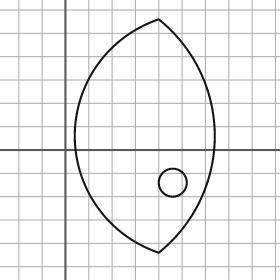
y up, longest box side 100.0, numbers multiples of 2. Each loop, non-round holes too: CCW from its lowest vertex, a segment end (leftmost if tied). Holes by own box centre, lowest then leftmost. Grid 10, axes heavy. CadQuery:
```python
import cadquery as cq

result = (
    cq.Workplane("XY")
    .moveTo(40.0, -44.0)
    .threePointArc((64.0, 6.0), (40.0, 56.0))
    .threePointArc((4.0, 6.0), (40.0, -44.0))
    .close()
    .moveTo(46.0, -14.0)
    .circle(6.0)
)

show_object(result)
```